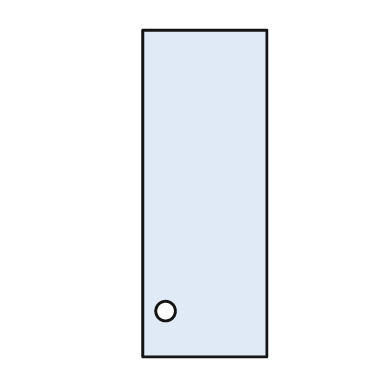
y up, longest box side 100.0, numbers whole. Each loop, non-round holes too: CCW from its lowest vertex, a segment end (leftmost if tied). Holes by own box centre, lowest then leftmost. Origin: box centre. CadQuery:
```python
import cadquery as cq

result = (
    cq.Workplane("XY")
    .moveTo(-19.0, -50.0)
    .lineTo(19.0, -50.0)
    .lineTo(19.0, 50.0)
    .lineTo(-19.0, 50.0)
    .close()
    .moveTo(-12.0, -36.0)
    .circle(3.0)
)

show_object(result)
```